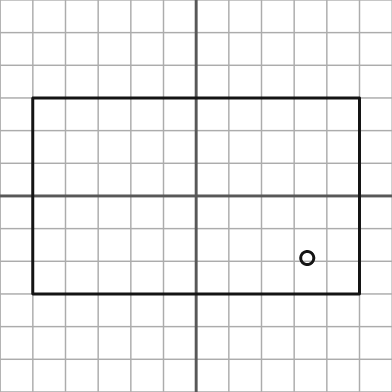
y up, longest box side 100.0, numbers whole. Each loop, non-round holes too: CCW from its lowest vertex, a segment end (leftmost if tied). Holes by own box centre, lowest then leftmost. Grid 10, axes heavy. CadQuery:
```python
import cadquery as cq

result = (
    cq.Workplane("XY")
    .moveTo(-50.0, -30.0)
    .lineTo(50.0, -30.0)
    .lineTo(50.0, 30.0)
    .lineTo(-50.0, 30.0)
    .close()
    .moveTo(34.0, -19.0)
    .circle(2.0)
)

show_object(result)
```